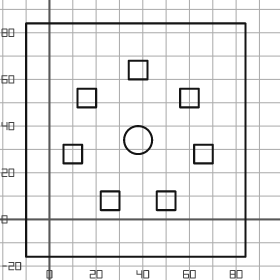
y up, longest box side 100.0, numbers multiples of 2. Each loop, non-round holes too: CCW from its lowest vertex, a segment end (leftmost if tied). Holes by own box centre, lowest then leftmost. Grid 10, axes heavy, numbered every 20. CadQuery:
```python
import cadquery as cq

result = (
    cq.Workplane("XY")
    .moveTo(-10.0, -16.0)
    .lineTo(84.0, -16.0)
    .lineTo(84.0, 84.0)
    .lineTo(-10.0, 84.0)
    .close()
    .moveTo(22.0, 4.0)
    .lineTo(30.0, 4.0)
    .lineTo(30.0, 12.0)
    .lineTo(22.0, 12.0)
    .close()
    .moveTo(46.0, 4.0)
    .lineTo(54.0, 4.0)
    .lineTo(54.0, 12.0)
    .lineTo(46.0, 12.0)
    .close()
    .moveTo(6.0, 24.0)
    .lineTo(14.0, 24.0)
    .lineTo(14.0, 32.0)
    .lineTo(6.0, 32.0)
    .close()
    .moveTo(62.0, 24.0)
    .lineTo(70.0, 24.0)
    .lineTo(70.0, 32.0)
    .lineTo(62.0, 32.0)
    .close()
    .moveTo(38.0, 34.0)
    .circle(6.0)
    .moveTo(12.0, 48.0)
    .lineTo(20.0, 48.0)
    .lineTo(20.0, 56.0)
    .lineTo(12.0, 56.0)
    .close()
    .moveTo(56.0, 48.0)
    .lineTo(64.0, 48.0)
    .lineTo(64.0, 56.0)
    .lineTo(56.0, 56.0)
    .close()
    .moveTo(34.0, 60.0)
    .lineTo(42.0, 60.0)
    .lineTo(42.0, 68.0)
    .lineTo(34.0, 68.0)
    .close()
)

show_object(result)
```